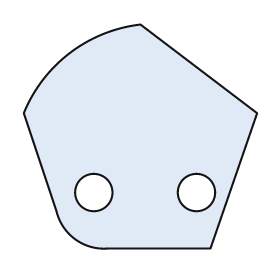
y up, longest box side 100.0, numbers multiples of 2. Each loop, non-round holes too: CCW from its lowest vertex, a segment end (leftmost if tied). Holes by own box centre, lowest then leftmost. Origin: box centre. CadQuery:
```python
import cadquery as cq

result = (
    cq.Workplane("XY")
    .moveTo(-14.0, -48.0)
    .lineTo(30.0, -48.0)
    .lineTo(50.0, 10.0)
    .lineTo(0.0, 48.0)
    .threePointArc((-30.0, 36.0), (-50.0, 10.0))
    .lineTo(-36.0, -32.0)
    .threePointArc((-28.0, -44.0), (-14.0, -48.0))
    .close()
    .moveTo(-20.0, -24.0)
    .circle(8.0)
    .moveTo(24.0, -24.0)
    .circle(8.0)
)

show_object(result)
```